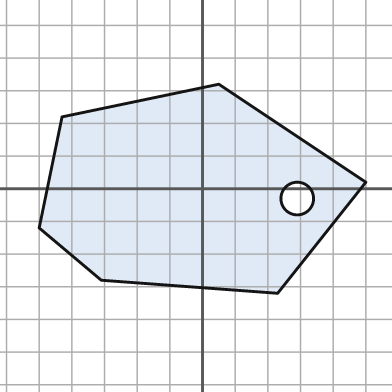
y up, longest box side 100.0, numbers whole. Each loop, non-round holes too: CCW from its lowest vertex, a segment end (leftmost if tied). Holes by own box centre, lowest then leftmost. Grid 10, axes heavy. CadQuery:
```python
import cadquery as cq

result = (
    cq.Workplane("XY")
    .moveTo(23.0, -32.0)
    .lineTo(50.0, 2.0)
    .lineTo(5.0, 32.0)
    .lineTo(-43.0, 22.0)
    .lineTo(-50.0, -12.0)
    .lineTo(-31.0, -28.0)
    .close()
    .moveTo(29.0, -3.0)
    .circle(5.0)
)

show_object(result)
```